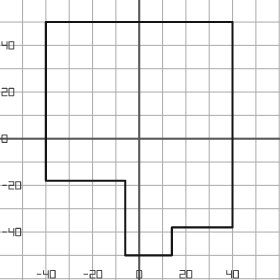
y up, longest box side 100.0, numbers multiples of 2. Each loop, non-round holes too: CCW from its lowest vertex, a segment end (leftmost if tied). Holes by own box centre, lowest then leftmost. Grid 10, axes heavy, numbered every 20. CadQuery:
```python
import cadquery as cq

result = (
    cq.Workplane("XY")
    .moveTo(-6.0, -50.0)
    .lineTo(14.0, -50.0)
    .lineTo(14.0, -38.0)
    .lineTo(40.0, -38.0)
    .lineTo(40.0, 50.0)
    .lineTo(-40.0, 50.0)
    .lineTo(-40.0, -18.0)
    .lineTo(-6.0, -18.0)
    .close()
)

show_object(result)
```